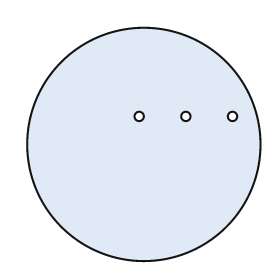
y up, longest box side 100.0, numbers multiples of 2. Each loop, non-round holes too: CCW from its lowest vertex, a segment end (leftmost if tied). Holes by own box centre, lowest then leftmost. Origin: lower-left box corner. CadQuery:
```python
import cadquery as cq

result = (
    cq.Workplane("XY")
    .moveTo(50.0, 50.0)
    .circle(50.0)
    .moveTo(48.0, 62.0)
    .circle(2.0)
    .moveTo(68.0, 62.0)
    .circle(2.0)
    .moveTo(88.0, 62.0)
    .circle(2.0)
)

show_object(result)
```